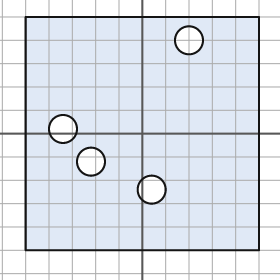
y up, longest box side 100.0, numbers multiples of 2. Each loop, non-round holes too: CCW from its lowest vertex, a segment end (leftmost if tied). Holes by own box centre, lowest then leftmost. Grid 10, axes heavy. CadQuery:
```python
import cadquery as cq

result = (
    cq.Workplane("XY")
    .moveTo(-50.0, -50.0)
    .lineTo(50.0, -50.0)
    .lineTo(50.0, 50.0)
    .lineTo(-50.0, 50.0)
    .close()
    .moveTo(4.0, -24.0)
    .circle(6.0)
    .moveTo(-22.0, -12.0)
    .circle(6.0)
    .moveTo(-34.0, 2.0)
    .circle(6.0)
    .moveTo(20.0, 40.0)
    .circle(6.0)
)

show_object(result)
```